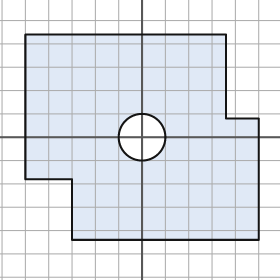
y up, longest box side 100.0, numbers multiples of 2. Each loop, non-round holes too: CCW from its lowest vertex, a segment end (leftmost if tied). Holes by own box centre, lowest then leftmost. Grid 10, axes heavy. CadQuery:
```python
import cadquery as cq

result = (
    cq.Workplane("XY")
    .moveTo(-30.0, -44.0)
    .lineTo(50.0, -44.0)
    .lineTo(50.0, 8.0)
    .lineTo(36.0, 8.0)
    .lineTo(36.0, 44.0)
    .lineTo(-50.0, 44.0)
    .lineTo(-50.0, -18.0)
    .lineTo(-30.0, -18.0)
    .close()
    .moveTo(0.0, 0.0)
    .circle(10.0)
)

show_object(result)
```